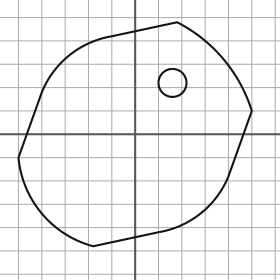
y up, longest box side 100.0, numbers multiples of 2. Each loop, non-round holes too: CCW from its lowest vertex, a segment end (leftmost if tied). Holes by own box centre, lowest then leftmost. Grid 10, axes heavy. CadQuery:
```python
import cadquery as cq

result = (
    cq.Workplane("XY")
    .moveTo(-18.0, -48.0)
    .lineTo(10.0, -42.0)
    .threePointArc((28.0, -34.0), (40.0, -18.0))
    .lineTo(50.0, 10.0)
    .threePointArc((38.0, 32.0), (18.0, 48.0))
    .lineTo(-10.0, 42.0)
    .threePointArc((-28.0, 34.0), (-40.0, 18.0))
    .lineTo(-50.0, -10.0)
    .threePointArc((-40.0, -34.0), (-18.0, -48.0))
    .close()
    .moveTo(16.0, 22.0)
    .circle(6.0)
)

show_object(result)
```